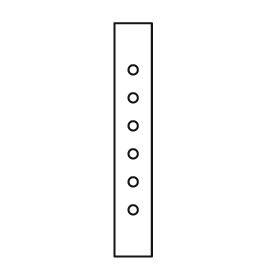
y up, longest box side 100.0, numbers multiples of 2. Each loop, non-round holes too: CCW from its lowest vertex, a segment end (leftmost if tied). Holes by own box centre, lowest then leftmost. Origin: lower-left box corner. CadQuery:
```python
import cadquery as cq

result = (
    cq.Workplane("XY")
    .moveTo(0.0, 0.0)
    .lineTo(16.0, 0.0)
    .lineTo(16.0, 100.0)
    .lineTo(0.0, 100.0)
    .close()
    .moveTo(8.0, 20.0)
    .circle(2.0)
    .moveTo(8.0, 32.0)
    .circle(2.0)
    .moveTo(8.0, 44.0)
    .circle(2.0)
    .moveTo(8.0, 56.0)
    .circle(2.0)
    .moveTo(8.0, 68.0)
    .circle(2.0)
    .moveTo(8.0, 80.0)
    .circle(2.0)
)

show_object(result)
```